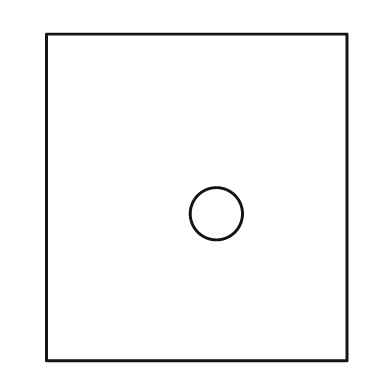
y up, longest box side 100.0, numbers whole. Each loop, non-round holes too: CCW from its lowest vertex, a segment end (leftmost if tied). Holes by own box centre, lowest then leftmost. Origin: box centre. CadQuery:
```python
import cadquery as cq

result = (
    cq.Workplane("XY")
    .moveTo(-46.0, -50.0)
    .lineTo(46.0, -50.0)
    .lineTo(46.0, 50.0)
    .lineTo(-46.0, 50.0)
    .close()
    .moveTo(6.0, -5.0)
    .circle(8.0)
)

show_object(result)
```